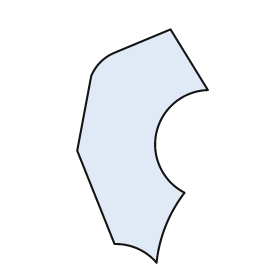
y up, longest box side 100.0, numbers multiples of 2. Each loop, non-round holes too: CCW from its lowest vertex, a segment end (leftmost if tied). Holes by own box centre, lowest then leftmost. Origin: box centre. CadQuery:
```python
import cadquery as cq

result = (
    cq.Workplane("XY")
    .moveTo(6.0, -50.0)
    .threePointArc((10.0, -34.0), (18.0, -20.0))
    .threePointArc((6.0, 6.0), (28.0, 24.0))
    .lineTo(12.0, 50.0)
    .lineTo(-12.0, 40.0)
    .threePointArc((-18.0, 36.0), (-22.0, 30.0))
    .lineTo(-28.0, -2.0)
    .lineTo(-12.0, -42.0)
    .threePointArc((-2.0, -44.0), (6.0, -50.0))
    .close()
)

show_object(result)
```